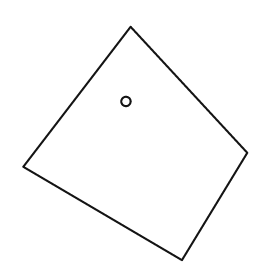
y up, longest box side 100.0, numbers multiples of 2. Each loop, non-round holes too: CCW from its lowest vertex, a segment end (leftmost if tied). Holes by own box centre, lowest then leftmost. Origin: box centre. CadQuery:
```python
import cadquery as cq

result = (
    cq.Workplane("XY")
    .moveTo(20.0, -50.0)
    .lineTo(48.0, -4.0)
    .lineTo(-2.0, 50.0)
    .lineTo(-48.0, -10.0)
    .close()
    .moveTo(-4.0, 18.0)
    .circle(2.0)
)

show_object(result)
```